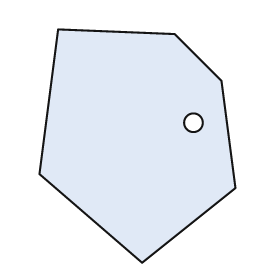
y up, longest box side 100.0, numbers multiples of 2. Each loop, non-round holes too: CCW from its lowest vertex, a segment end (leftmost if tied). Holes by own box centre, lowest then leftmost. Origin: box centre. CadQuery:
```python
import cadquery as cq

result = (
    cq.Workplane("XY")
    .moveTo(2.0, -50.0)
    .lineTo(42.0, -18.0)
    .lineTo(36.0, 28.0)
    .lineTo(16.0, 48.0)
    .lineTo(-34.0, 50.0)
    .lineTo(-42.0, -12.0)
    .close()
    .moveTo(24.0, 10.0)
    .circle(4.0)
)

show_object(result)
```